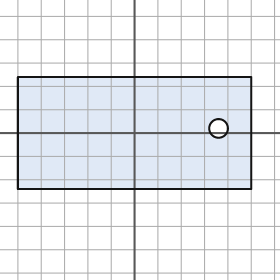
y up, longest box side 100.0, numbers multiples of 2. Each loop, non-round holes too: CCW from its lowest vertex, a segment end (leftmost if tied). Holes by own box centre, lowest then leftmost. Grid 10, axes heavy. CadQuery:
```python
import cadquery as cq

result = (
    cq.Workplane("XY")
    .moveTo(-50.0, -24.0)
    .lineTo(50.0, -24.0)
    .lineTo(50.0, 24.0)
    .lineTo(-50.0, 24.0)
    .close()
    .moveTo(36.0, 2.0)
    .circle(4.0)
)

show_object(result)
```